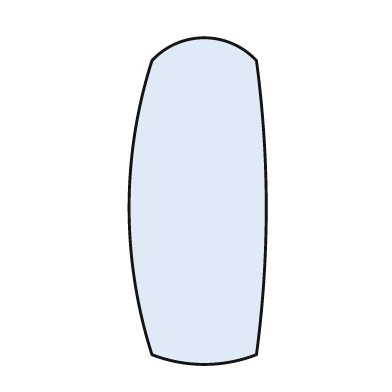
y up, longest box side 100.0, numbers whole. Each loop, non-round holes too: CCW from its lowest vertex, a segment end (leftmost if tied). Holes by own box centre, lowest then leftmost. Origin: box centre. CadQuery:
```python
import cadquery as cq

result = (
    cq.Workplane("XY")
    .moveTo(-14.0, -47.0)
    .threePointArc((2.0, -50.0), (18.0, -47.0))
    .threePointArc((21.0, -2.0), (18.0, 43.0))
    .threePointArc((2.0, 50.0), (-14.0, 43.0))
    .threePointArc((-21.0, -2.0), (-14.0, -47.0))
    .close()
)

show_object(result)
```